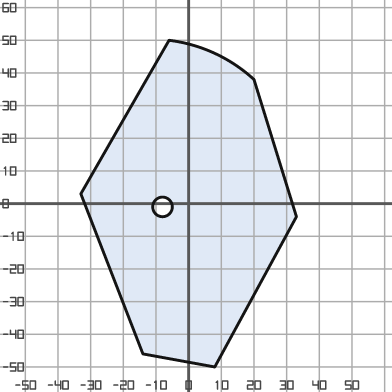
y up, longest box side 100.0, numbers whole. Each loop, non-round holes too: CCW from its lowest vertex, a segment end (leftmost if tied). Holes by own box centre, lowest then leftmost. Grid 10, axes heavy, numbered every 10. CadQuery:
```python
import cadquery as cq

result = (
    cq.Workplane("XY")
    .moveTo(8.0, -50.0)
    .lineTo(33.0, -4.0)
    .lineTo(20.0, 38.0)
    .threePointArc((8.0, 46.0), (-6.0, 50.0))
    .lineTo(-33.0, 3.0)
    .lineTo(-14.0, -46.0)
    .close()
    .moveTo(-8.0, -1.0)
    .circle(3.0)
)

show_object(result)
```